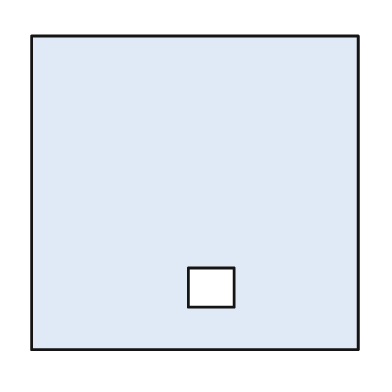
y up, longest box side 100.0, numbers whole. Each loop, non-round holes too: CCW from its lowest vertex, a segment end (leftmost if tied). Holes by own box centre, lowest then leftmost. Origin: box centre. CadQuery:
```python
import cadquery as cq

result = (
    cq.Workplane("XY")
    .moveTo(-50.0, -48.0)
    .lineTo(50.0, -48.0)
    .lineTo(50.0, 48.0)
    .lineTo(-50.0, 48.0)
    .close()
    .moveTo(-2.0, -35.0)
    .lineTo(12.0, -35.0)
    .lineTo(12.0, -23.0)
    .lineTo(-2.0, -23.0)
    .close()
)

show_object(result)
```